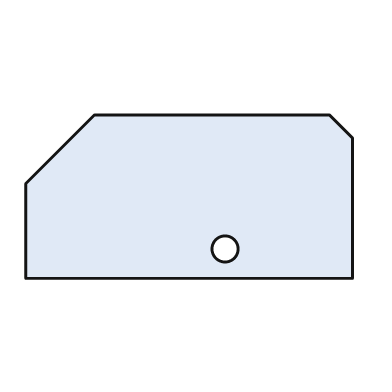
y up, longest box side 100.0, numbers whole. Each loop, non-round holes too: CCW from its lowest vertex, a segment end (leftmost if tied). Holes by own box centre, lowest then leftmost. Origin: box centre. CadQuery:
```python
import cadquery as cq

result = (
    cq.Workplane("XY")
    .moveTo(-50.0, -25.0)
    .lineTo(50.0, -25.0)
    .lineTo(50.0, 18.0)
    .lineTo(43.0, 25.0)
    .lineTo(-29.0, 25.0)
    .lineTo(-50.0, 4.0)
    .close()
    .moveTo(11.0, -16.0)
    .circle(4.0)
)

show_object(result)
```